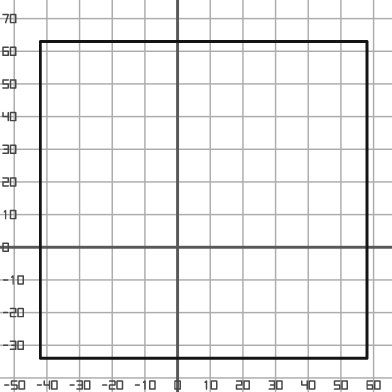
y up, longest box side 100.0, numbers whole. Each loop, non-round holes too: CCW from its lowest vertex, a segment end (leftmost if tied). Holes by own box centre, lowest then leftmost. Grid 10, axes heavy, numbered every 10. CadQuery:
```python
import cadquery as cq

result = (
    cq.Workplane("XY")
    .moveTo(-42.0, -34.0)
    .lineTo(58.0, -34.0)
    .lineTo(58.0, 63.0)
    .lineTo(-42.0, 63.0)
    .close()
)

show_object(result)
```